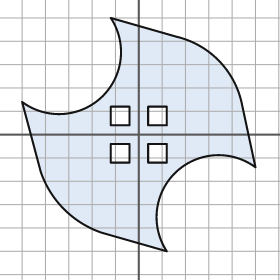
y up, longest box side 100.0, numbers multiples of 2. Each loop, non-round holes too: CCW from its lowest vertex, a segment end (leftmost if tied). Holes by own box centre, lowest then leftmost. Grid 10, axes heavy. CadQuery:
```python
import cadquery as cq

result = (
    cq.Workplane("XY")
    .moveTo(12.0, -50.0)
    .threePointArc((16.0, -16.0), (50.0, -14.0))
    .lineTo(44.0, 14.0)
    .threePointArc((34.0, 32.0), (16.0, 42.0))
    .lineTo(-12.0, 50.0)
    .threePointArc((-16.0, 16.0), (-50.0, 14.0))
    .lineTo(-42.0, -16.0)
    .threePointArc((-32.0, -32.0), (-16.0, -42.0))
    .close()
    .moveTo(-12.0, -12.0)
    .lineTo(-4.0, -12.0)
    .lineTo(-4.0, -4.0)
    .lineTo(-12.0, -4.0)
    .close()
    .moveTo(4.0, -12.0)
    .lineTo(12.0, -12.0)
    .lineTo(12.0, -4.0)
    .lineTo(4.0, -4.0)
    .close()
    .moveTo(-12.0, 4.0)
    .lineTo(-4.0, 4.0)
    .lineTo(-4.0, 12.0)
    .lineTo(-12.0, 12.0)
    .close()
    .moveTo(4.0, 4.0)
    .lineTo(12.0, 4.0)
    .lineTo(12.0, 12.0)
    .lineTo(4.0, 12.0)
    .close()
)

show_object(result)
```